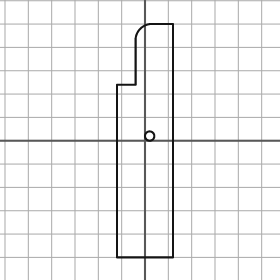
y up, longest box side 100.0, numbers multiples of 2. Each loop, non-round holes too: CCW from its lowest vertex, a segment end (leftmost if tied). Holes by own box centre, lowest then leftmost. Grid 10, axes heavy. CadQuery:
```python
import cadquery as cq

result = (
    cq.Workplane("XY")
    .moveTo(-12.0, -50.0)
    .lineTo(12.0, -50.0)
    .lineTo(12.0, 50.0)
    .lineTo(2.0, 50.0)
    .threePointArc((-2.0, 48.0), (-4.0, 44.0))
    .lineTo(-4.0, 24.0)
    .lineTo(-12.0, 24.0)
    .close()
    .moveTo(2.0, 2.0)
    .circle(2.0)
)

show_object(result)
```